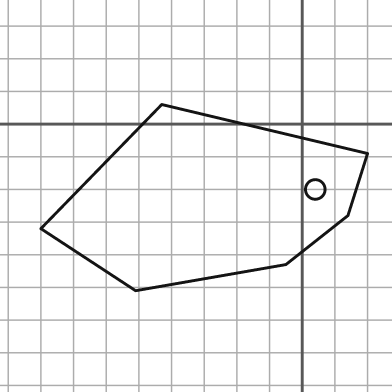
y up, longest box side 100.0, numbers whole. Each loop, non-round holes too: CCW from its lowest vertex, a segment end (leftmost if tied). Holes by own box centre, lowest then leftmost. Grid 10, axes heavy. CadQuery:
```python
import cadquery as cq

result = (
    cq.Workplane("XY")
    .moveTo(-51.0, -51.0)
    .lineTo(-5.0, -43.0)
    .lineTo(14.0, -28.0)
    .lineTo(20.0, -9.0)
    .lineTo(-43.0, 6.0)
    .lineTo(-80.0, -32.0)
    .close()
    .moveTo(4.0, -20.0)
    .circle(3.0)
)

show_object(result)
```